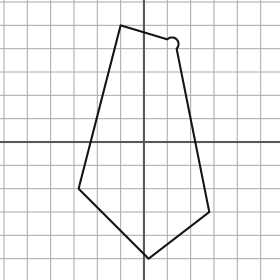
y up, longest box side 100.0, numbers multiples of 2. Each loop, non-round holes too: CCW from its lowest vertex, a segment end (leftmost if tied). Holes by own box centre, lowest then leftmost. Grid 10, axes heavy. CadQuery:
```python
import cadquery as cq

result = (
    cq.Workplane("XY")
    .moveTo(2.0, -50.0)
    .lineTo(28.0, -30.0)
    .lineTo(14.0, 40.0)
    .threePointArc((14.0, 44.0), (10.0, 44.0))
    .lineTo(-10.0, 50.0)
    .lineTo(-28.0, -20.0)
    .close()
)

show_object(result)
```